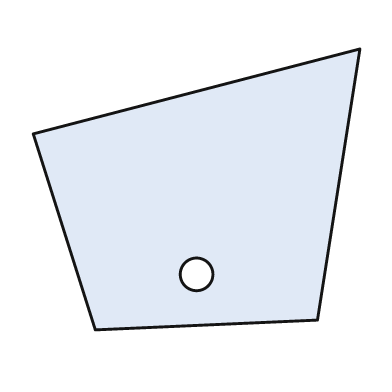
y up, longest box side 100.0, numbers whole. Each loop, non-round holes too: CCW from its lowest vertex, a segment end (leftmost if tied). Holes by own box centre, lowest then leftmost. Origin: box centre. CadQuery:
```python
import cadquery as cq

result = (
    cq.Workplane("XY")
    .moveTo(-31.0, -43.0)
    .lineTo(37.0, -40.0)
    .lineTo(50.0, 43.0)
    .lineTo(-50.0, 17.0)
    .close()
    .moveTo(0.0, -26.0)
    .circle(5.0)
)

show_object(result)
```